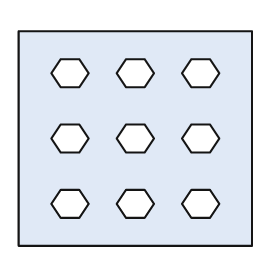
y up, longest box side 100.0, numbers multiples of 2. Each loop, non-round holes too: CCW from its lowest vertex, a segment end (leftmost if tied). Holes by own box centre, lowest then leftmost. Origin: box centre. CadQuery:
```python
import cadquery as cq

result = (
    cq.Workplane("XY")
    .moveTo(-50.0, -46.0)
    .lineTo(50.0, -46.0)
    .lineTo(50.0, 46.0)
    .lineTo(-50.0, 46.0)
    .close()
    .moveTo(-32.0, -34.0)
    .lineTo(-24.0, -34.0)
    .lineTo(-20.0, -28.0)
    .lineTo(-24.0, -22.0)
    .lineTo(-32.0, -22.0)
    .lineTo(-36.0, -28.0)
    .close()
    .moveTo(-4.0, -34.0)
    .lineTo(4.0, -34.0)
    .lineTo(8.0, -28.0)
    .lineTo(4.0, -22.0)
    .lineTo(-4.0, -22.0)
    .lineTo(-8.0, -28.0)
    .close()
    .moveTo(24.0, -34.0)
    .lineTo(32.0, -34.0)
    .lineTo(36.0, -28.0)
    .lineTo(32.0, -22.0)
    .lineTo(24.0, -22.0)
    .lineTo(20.0, -28.0)
    .close()
    .moveTo(-32.0, -6.0)
    .lineTo(-24.0, -6.0)
    .lineTo(-20.0, 0.0)
    .lineTo(-24.0, 6.0)
    .lineTo(-32.0, 6.0)
    .lineTo(-36.0, 0.0)
    .close()
    .moveTo(-4.0, -6.0)
    .lineTo(4.0, -6.0)
    .lineTo(8.0, 0.0)
    .lineTo(4.0, 6.0)
    .lineTo(-4.0, 6.0)
    .lineTo(-8.0, 0.0)
    .close()
    .moveTo(24.0, -6.0)
    .lineTo(32.0, -6.0)
    .lineTo(36.0, 0.0)
    .lineTo(32.0, 6.0)
    .lineTo(24.0, 6.0)
    .lineTo(20.0, 0.0)
    .close()
    .moveTo(-32.0, 22.0)
    .lineTo(-24.0, 22.0)
    .lineTo(-20.0, 28.0)
    .lineTo(-24.0, 34.0)
    .lineTo(-32.0, 34.0)
    .lineTo(-36.0, 28.0)
    .close()
    .moveTo(-4.0, 22.0)
    .lineTo(4.0, 22.0)
    .lineTo(8.0, 28.0)
    .lineTo(4.0, 34.0)
    .lineTo(-4.0, 34.0)
    .lineTo(-8.0, 28.0)
    .close()
    .moveTo(24.0, 22.0)
    .lineTo(32.0, 22.0)
    .lineTo(36.0, 28.0)
    .lineTo(32.0, 34.0)
    .lineTo(24.0, 34.0)
    .lineTo(20.0, 28.0)
    .close()
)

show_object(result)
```